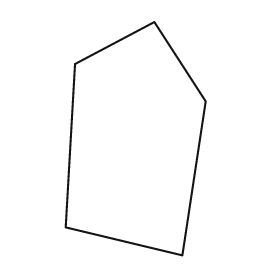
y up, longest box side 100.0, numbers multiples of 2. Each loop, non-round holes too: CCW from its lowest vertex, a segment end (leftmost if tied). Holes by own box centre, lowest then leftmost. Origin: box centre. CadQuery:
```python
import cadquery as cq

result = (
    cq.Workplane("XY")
    .moveTo(20.0, -50.0)
    .lineTo(30.0, 16.0)
    .lineTo(8.0, 50.0)
    .lineTo(-26.0, 32.0)
    .lineTo(-30.0, -38.0)
    .close()
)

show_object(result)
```